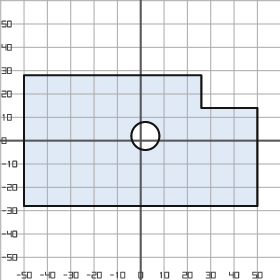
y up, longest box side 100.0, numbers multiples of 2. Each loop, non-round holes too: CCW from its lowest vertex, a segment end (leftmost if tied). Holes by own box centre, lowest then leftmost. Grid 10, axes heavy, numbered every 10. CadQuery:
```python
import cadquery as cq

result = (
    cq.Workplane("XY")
    .moveTo(-50.0, -28.0)
    .lineTo(50.0, -28.0)
    .lineTo(50.0, 14.0)
    .lineTo(26.0, 14.0)
    .lineTo(26.0, 28.0)
    .lineTo(-50.0, 28.0)
    .close()
    .moveTo(2.0, 2.0)
    .circle(6.0)
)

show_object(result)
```